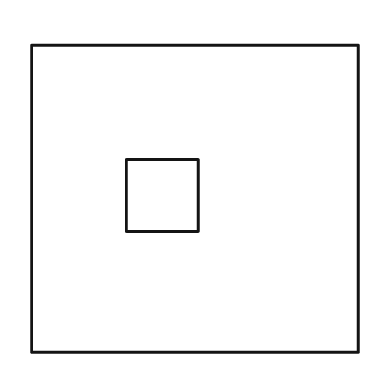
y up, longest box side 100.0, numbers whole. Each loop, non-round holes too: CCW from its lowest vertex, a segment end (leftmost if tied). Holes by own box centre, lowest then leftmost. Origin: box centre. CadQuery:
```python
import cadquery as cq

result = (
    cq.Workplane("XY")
    .moveTo(-50.0, -47.0)
    .lineTo(50.0, -47.0)
    .lineTo(50.0, 47.0)
    .lineTo(-50.0, 47.0)
    .close()
    .moveTo(-21.0, -10.0)
    .lineTo(1.0, -10.0)
    .lineTo(1.0, 12.0)
    .lineTo(-21.0, 12.0)
    .close()
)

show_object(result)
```